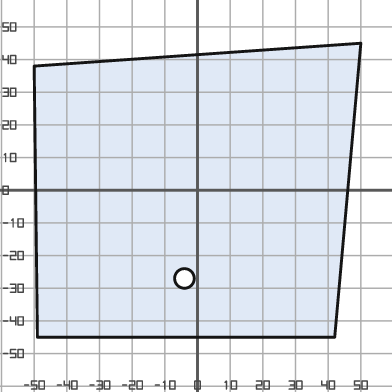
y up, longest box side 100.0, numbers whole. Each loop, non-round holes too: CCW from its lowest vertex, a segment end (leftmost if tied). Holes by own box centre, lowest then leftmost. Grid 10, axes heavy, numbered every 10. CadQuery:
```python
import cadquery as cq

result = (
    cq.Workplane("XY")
    .moveTo(-49.0, -45.0)
    .lineTo(42.0, -45.0)
    .lineTo(50.0, 45.0)
    .lineTo(-50.0, 38.0)
    .close()
    .moveTo(-4.0, -27.0)
    .circle(3.0)
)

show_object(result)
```